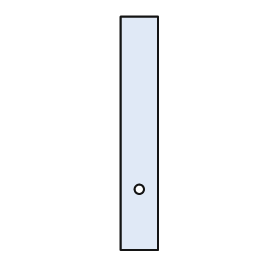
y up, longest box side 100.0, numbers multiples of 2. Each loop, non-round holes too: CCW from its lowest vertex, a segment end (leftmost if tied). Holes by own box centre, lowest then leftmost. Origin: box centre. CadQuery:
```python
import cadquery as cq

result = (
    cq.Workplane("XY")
    .moveTo(-8.0, -50.0)
    .lineTo(8.0, -50.0)
    .lineTo(8.0, 50.0)
    .lineTo(-8.0, 50.0)
    .close()
    .moveTo(0.0, -24.0)
    .circle(2.0)
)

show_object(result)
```